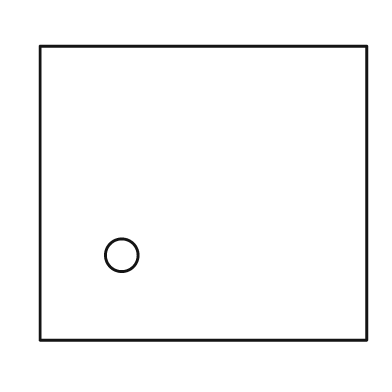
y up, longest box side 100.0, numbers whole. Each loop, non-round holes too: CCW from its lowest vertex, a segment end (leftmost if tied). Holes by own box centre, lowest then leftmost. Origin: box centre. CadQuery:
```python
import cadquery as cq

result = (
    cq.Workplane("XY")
    .moveTo(-50.0, -45.0)
    .lineTo(50.0, -45.0)
    .lineTo(50.0, 45.0)
    .lineTo(-50.0, 45.0)
    .close()
    .moveTo(-25.0, -19.0)
    .circle(5.0)
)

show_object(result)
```